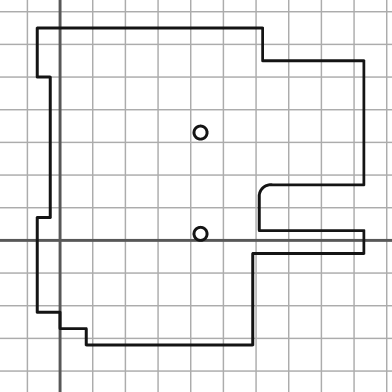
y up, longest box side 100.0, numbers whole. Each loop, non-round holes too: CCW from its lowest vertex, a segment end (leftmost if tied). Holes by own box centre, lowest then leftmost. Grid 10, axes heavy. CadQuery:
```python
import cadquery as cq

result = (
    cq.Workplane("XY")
    .moveTo(8.0, -32.0)
    .lineTo(59.0, -32.0)
    .lineTo(59.0, -4.0)
    .lineTo(93.0, -4.0)
    .lineTo(93.0, 3.0)
    .lineTo(61.0, 3.0)
    .lineTo(61.0, 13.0)
    .threePointArc((62.0, 16.0), (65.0, 17.0))
    .lineTo(93.0, 17.0)
    .lineTo(93.0, 55.0)
    .lineTo(62.0, 55.0)
    .lineTo(62.0, 65.0)
    .lineTo(-7.0, 65.0)
    .lineTo(-7.0, 50.0)
    .lineTo(-3.0, 50.0)
    .lineTo(-3.0, 7.0)
    .lineTo(-7.0, 7.0)
    .lineTo(-7.0, -22.0)
    .lineTo(0.0, -22.0)
    .lineTo(0.0, -27.0)
    .lineTo(8.0, -27.0)
    .close()
    .moveTo(43.0, 2.0)
    .circle(2.0)
    .moveTo(43.0, 33.0)
    .circle(2.0)
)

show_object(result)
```